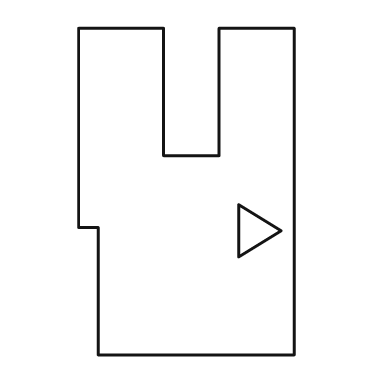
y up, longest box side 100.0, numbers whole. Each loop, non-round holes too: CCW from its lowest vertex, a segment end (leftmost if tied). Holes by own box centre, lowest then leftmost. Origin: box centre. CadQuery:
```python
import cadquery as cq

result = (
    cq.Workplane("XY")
    .moveTo(-27.0, -50.0)
    .lineTo(33.0, -50.0)
    .lineTo(33.0, 50.0)
    .lineTo(10.0, 50.0)
    .lineTo(10.0, 11.0)
    .lineTo(-7.0, 11.0)
    .lineTo(-7.0, 50.0)
    .lineTo(-33.0, 50.0)
    .lineTo(-33.0, -11.0)
    .lineTo(-27.0, -11.0)
    .close()
    .moveTo(16.0, -20.0)
    .lineTo(29.0, -12.0)
    .lineTo(16.0, -4.0)
    .close()
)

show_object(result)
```